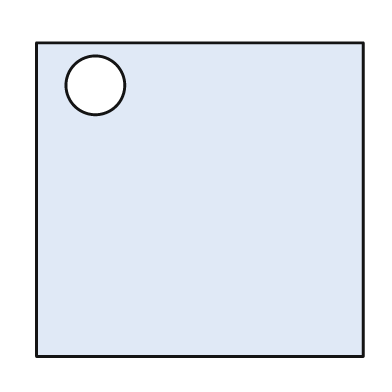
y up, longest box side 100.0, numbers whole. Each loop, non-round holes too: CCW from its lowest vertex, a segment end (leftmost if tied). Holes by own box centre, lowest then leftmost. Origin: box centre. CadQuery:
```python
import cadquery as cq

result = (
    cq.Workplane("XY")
    .moveTo(-50.0, -48.0)
    .lineTo(50.0, -48.0)
    .lineTo(50.0, 48.0)
    .lineTo(-50.0, 48.0)
    .close()
    .moveTo(-32.0, 35.0)
    .circle(9.0)
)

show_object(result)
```